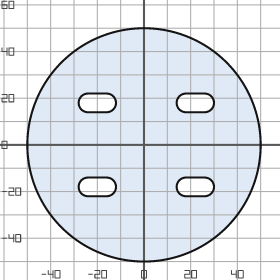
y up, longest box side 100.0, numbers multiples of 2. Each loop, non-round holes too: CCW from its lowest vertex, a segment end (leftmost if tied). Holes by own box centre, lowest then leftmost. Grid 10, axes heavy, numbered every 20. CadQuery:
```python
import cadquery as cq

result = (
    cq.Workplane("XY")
    .moveTo(0.0, 0.0)
    .circle(50.0)
    .moveTo(-24.0, -22.0)
    .lineTo(-16.0, -22.0)
    .threePointArc((-12.0, -18.0), (-16.0, -14.0))
    .lineTo(-24.0, -14.0)
    .threePointArc((-28.0, -18.0), (-24.0, -22.0))
    .close()
    .moveTo(18.0, -22.0)
    .lineTo(26.0, -22.0)
    .threePointArc((30.0, -18.0), (26.0, -14.0))
    .lineTo(18.0, -14.0)
    .threePointArc((14.0, -18.0), (18.0, -22.0))
    .close()
    .moveTo(-24.0, 14.0)
    .lineTo(-16.0, 14.0)
    .threePointArc((-12.0, 18.0), (-16.0, 22.0))
    .lineTo(-24.0, 22.0)
    .threePointArc((-28.0, 18.0), (-24.0, 14.0))
    .close()
    .moveTo(18.0, 14.0)
    .lineTo(26.0, 14.0)
    .threePointArc((30.0, 18.0), (26.0, 22.0))
    .lineTo(18.0, 22.0)
    .threePointArc((14.0, 18.0), (18.0, 14.0))
    .close()
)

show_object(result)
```